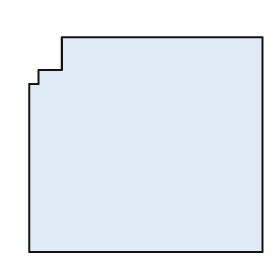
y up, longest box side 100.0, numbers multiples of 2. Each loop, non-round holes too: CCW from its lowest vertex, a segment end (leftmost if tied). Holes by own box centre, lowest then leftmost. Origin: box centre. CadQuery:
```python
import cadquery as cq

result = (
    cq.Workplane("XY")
    .moveTo(-50.0, -46.0)
    .lineTo(50.0, -46.0)
    .lineTo(50.0, 46.0)
    .lineTo(-36.0, 46.0)
    .lineTo(-36.0, 32.0)
    .lineTo(-46.0, 32.0)
    .lineTo(-46.0, 26.0)
    .lineTo(-50.0, 26.0)
    .close()
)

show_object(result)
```